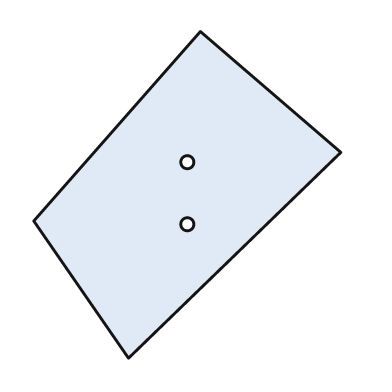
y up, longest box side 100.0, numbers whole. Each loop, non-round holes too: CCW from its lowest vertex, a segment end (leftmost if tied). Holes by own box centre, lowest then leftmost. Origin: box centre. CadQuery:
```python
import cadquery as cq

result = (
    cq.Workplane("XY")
    .moveTo(-18.0, -50.0)
    .lineTo(47.0, 13.0)
    .lineTo(4.0, 50.0)
    .lineTo(-47.0, -8.0)
    .close()
    .moveTo(0.0, -9.0)
    .circle(2.0)
    .moveTo(0.0, 10.0)
    .circle(2.0)
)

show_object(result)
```